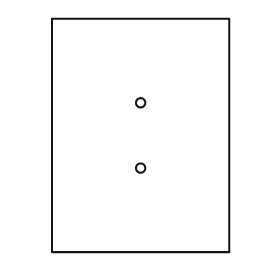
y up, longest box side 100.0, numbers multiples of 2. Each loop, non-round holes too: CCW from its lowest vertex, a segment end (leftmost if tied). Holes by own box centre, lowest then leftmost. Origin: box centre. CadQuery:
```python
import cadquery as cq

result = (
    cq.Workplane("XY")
    .moveTo(-38.0, -50.0)
    .lineTo(38.0, -50.0)
    .lineTo(38.0, 50.0)
    .lineTo(-38.0, 50.0)
    .close()
    .moveTo(0.0, -14.0)
    .circle(2.0)
    .moveTo(0.0, 14.0)
    .circle(2.0)
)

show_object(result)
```